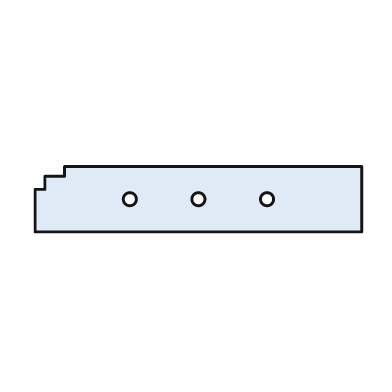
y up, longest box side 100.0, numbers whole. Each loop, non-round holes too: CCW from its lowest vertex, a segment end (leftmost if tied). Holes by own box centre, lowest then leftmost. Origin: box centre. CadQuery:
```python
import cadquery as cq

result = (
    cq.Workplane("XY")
    .moveTo(-50.0, -10.0)
    .lineTo(50.0, -10.0)
    .lineTo(50.0, 10.0)
    .lineTo(-41.0, 10.0)
    .lineTo(-41.0, 7.0)
    .lineTo(-47.0, 7.0)
    .lineTo(-47.0, 3.0)
    .lineTo(-50.0, 3.0)
    .close()
    .moveTo(-21.0, 0.0)
    .circle(2.0)
    .moveTo(0.0, 0.0)
    .circle(2.0)
    .moveTo(21.0, 0.0)
    .circle(2.0)
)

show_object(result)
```